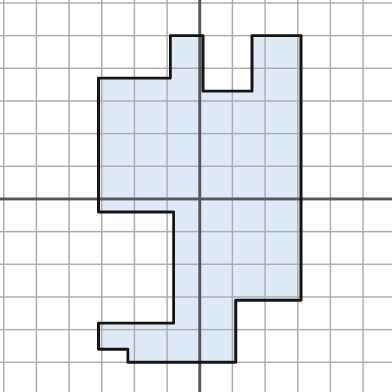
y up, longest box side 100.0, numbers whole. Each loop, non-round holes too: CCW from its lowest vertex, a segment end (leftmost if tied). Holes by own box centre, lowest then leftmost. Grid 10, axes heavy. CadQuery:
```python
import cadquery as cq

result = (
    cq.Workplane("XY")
    .moveTo(-22.0, -50.0)
    .lineTo(11.0, -50.0)
    .lineTo(11.0, -31.0)
    .lineTo(31.0, -31.0)
    .lineTo(31.0, 50.0)
    .lineTo(16.0, 50.0)
    .lineTo(16.0, 33.0)
    .lineTo(1.0, 33.0)
    .lineTo(1.0, 50.0)
    .lineTo(-9.0, 50.0)
    .lineTo(-9.0, 37.0)
    .lineTo(-31.0, 37.0)
    .lineTo(-31.0, -4.0)
    .lineTo(-8.0, -4.0)
    .lineTo(-8.0, -38.0)
    .lineTo(-31.0, -38.0)
    .lineTo(-31.0, -46.0)
    .lineTo(-22.0, -46.0)
    .close()
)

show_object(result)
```